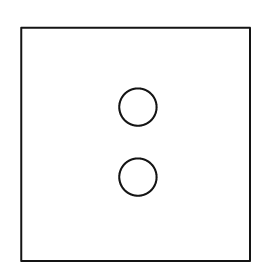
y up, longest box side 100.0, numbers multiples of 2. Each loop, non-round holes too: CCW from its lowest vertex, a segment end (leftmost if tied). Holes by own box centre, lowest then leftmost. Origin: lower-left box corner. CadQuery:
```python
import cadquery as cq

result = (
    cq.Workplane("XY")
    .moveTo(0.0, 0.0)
    .lineTo(98.0, 0.0)
    .lineTo(98.0, 100.0)
    .lineTo(0.0, 100.0)
    .close()
    .moveTo(50.0, 36.0)
    .circle(8.0)
    .moveTo(50.0, 66.0)
    .circle(8.0)
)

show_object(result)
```